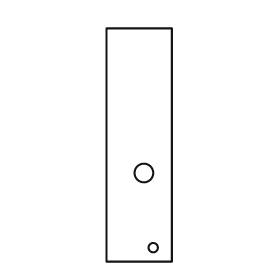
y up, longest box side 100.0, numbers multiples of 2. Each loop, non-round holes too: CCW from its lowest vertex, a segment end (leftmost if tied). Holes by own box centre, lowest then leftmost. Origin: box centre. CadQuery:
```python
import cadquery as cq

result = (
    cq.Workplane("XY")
    .moveTo(-14.0, -50.0)
    .lineTo(14.0, -50.0)
    .lineTo(14.0, 50.0)
    .lineTo(-14.0, 50.0)
    .close()
    .moveTo(6.0, -44.0)
    .circle(2.0)
    .moveTo(2.0, -12.0)
    .circle(4.0)
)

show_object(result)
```